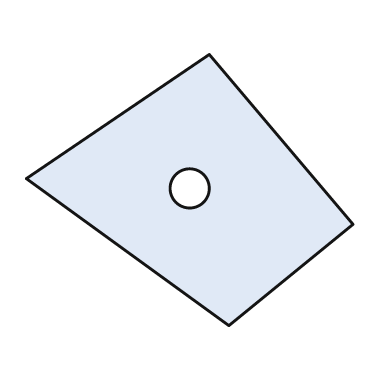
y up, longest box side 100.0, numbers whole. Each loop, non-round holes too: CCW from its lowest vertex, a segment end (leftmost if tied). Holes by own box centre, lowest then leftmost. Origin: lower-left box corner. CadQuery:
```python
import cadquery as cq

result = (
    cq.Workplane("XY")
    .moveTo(62.0, 0.0)
    .lineTo(100.0, 31.0)
    .lineTo(56.0, 83.0)
    .lineTo(0.0, 45.0)
    .close()
    .moveTo(50.0, 42.0)
    .circle(6.0)
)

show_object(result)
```